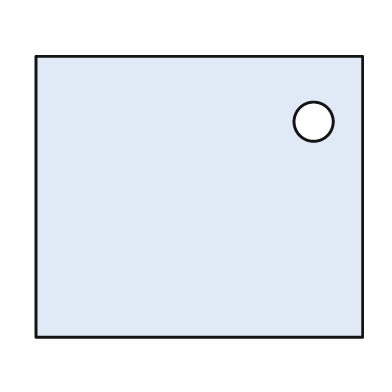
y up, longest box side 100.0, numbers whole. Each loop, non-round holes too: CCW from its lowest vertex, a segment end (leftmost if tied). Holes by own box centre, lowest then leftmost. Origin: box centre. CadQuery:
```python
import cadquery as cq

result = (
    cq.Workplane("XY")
    .moveTo(-50.0, -43.0)
    .lineTo(50.0, -43.0)
    .lineTo(50.0, 43.0)
    .lineTo(-50.0, 43.0)
    .close()
    .moveTo(35.0, 23.0)
    .circle(6.0)
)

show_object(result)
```